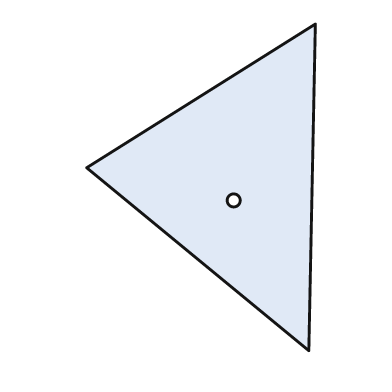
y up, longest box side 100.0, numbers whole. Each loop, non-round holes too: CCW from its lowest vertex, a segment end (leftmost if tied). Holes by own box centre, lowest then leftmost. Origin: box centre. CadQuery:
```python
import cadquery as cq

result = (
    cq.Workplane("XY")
    .moveTo(33.0, -50.0)
    .lineTo(35.0, 50.0)
    .lineTo(-35.0, 6.0)
    .close()
    .moveTo(10.0, -4.0)
    .circle(2.0)
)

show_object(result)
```